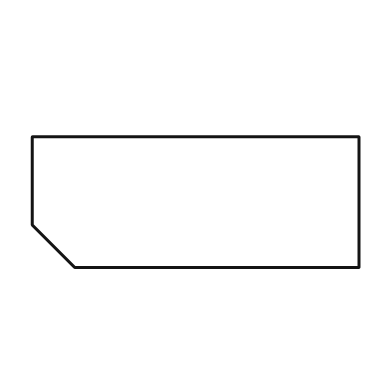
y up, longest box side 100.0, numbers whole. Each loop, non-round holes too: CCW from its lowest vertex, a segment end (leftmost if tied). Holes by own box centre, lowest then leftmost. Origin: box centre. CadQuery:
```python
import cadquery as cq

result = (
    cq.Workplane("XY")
    .moveTo(-37.0, -20.0)
    .lineTo(50.0, -20.0)
    .lineTo(50.0, 20.0)
    .lineTo(-50.0, 20.0)
    .lineTo(-50.0, -7.0)
    .close()
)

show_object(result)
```